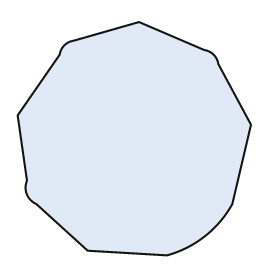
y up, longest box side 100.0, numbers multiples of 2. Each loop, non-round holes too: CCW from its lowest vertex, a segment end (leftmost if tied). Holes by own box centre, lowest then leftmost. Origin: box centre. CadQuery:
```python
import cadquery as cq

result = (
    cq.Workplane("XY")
    .moveTo(14.0, -50.0)
    .threePointArc((30.0, -42.0), (42.0, -28.0))
    .lineTo(50.0, 6.0)
    .lineTo(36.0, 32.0)
    .threePointArc((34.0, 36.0), (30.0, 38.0))
    .lineTo(2.0, 50.0)
    .lineTo(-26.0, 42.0)
    .threePointArc((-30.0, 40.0), (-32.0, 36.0))
    .lineTo(-50.0, 10.0)
    .lineTo(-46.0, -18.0)
    .threePointArc((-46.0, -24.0), (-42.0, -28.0))
    .lineTo(-20.0, -48.0)
    .close()
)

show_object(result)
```